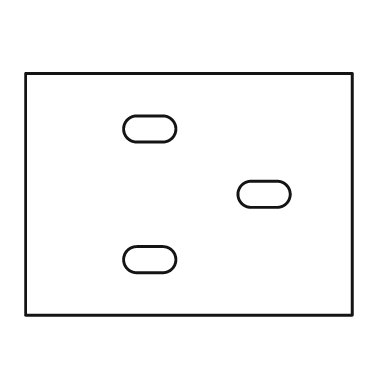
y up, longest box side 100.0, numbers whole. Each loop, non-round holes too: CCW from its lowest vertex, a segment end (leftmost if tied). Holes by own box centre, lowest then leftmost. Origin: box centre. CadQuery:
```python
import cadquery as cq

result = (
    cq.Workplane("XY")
    .moveTo(-50.0, -37.0)
    .lineTo(50.0, -37.0)
    .lineTo(50.0, 37.0)
    .lineTo(-50.0, 37.0)
    .close()
    .moveTo(-16.0, -24.0)
    .lineTo(-8.0, -24.0)
    .threePointArc((-4.0, -20.0), (-8.0, -16.0))
    .lineTo(-16.0, -16.0)
    .threePointArc((-20.0, -20.0), (-16.0, -24.0))
    .close()
    .moveTo(19.0, -4.0)
    .lineTo(27.0, -4.0)
    .threePointArc((31.0, 0.0), (27.0, 4.0))
    .lineTo(19.0, 4.0)
    .threePointArc((15.0, 0.0), (19.0, -4.0))
    .close()
    .moveTo(-16.0, 16.0)
    .lineTo(-8.0, 16.0)
    .threePointArc((-4.0, 20.0), (-8.0, 24.0))
    .lineTo(-16.0, 24.0)
    .threePointArc((-20.0, 20.0), (-16.0, 16.0))
    .close()
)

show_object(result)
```